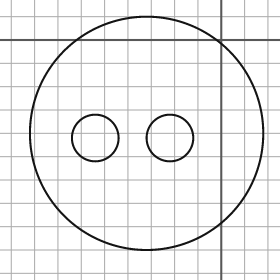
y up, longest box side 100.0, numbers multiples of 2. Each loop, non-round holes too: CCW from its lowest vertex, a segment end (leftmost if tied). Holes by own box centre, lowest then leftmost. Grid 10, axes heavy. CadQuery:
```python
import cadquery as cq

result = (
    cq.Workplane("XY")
    .moveTo(-32.0, -40.0)
    .circle(50.0)
    .moveTo(-54.0, -42.0)
    .circle(10.0)
    .moveTo(-22.0, -42.0)
    .circle(10.0)
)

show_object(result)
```